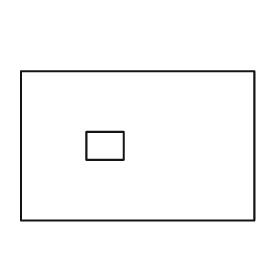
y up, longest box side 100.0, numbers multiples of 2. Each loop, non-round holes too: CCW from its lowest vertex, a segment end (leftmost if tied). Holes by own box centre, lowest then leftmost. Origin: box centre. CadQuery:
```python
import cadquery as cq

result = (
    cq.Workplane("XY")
    .moveTo(-50.0, -32.0)
    .lineTo(50.0, -32.0)
    .lineTo(50.0, 32.0)
    .lineTo(-50.0, 32.0)
    .close()
    .moveTo(-22.0, -6.0)
    .lineTo(-6.0, -6.0)
    .lineTo(-6.0, 6.0)
    .lineTo(-22.0, 6.0)
    .close()
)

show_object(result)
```